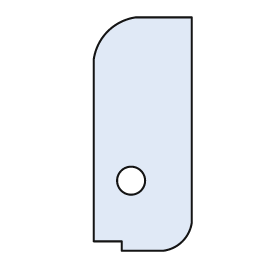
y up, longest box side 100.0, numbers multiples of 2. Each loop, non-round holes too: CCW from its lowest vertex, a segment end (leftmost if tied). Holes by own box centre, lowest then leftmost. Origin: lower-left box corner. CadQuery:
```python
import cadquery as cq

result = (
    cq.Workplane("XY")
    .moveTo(12.0, 0.0)
    .lineTo(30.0, 0.0)
    .threePointArc((38.0, 4.0), (42.0, 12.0))
    .lineTo(42.0, 100.0)
    .lineTo(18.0, 100.0)
    .threePointArc((6.0, 94.0), (0.0, 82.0))
    .lineTo(0.0, 4.0)
    .lineTo(12.0, 4.0)
    .close()
    .moveTo(16.0, 30.0)
    .circle(6.0)
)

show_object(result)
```